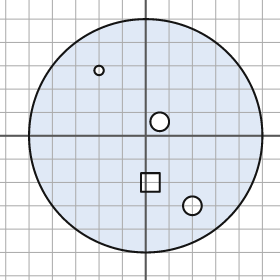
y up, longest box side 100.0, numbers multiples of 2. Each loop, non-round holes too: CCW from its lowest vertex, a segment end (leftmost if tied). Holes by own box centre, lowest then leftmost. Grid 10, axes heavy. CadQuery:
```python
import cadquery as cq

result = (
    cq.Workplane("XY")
    .moveTo(0.0, 0.0)
    .circle(50.0)
    .moveTo(20.0, -30.0)
    .circle(4.0)
    .moveTo(-2.0, -24.0)
    .lineTo(6.0, -24.0)
    .lineTo(6.0, -16.0)
    .lineTo(-2.0, -16.0)
    .close()
    .moveTo(6.0, 6.0)
    .circle(4.0)
    .moveTo(-20.0, 28.0)
    .circle(2.0)
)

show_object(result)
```